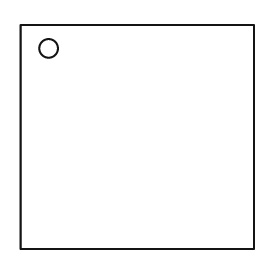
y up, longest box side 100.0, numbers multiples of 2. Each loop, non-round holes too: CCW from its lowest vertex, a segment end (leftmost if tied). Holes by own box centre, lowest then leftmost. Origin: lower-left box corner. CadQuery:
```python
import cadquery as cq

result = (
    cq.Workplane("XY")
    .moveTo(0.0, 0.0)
    .lineTo(100.0, 0.0)
    .lineTo(100.0, 96.0)
    .lineTo(0.0, 96.0)
    .close()
    .moveTo(12.0, 86.0)
    .circle(4.0)
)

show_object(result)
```